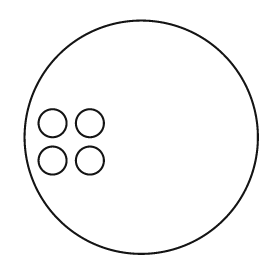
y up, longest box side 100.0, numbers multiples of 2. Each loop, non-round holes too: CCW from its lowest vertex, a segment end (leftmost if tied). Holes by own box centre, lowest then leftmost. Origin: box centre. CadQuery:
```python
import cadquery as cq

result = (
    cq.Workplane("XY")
    .moveTo(0.0, 0.0)
    .circle(50.0)
    .moveTo(-38.0, -10.0)
    .circle(6.0)
    .moveTo(-22.0, -10.0)
    .circle(6.0)
    .moveTo(-38.0, 6.0)
    .circle(6.0)
    .moveTo(-22.0, 6.0)
    .circle(6.0)
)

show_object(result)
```